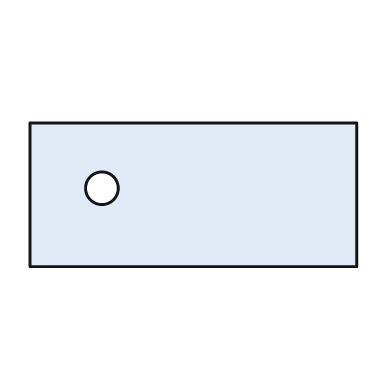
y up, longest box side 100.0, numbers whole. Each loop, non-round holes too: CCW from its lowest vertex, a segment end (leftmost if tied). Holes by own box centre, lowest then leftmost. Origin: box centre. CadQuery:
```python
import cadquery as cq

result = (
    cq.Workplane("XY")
    .moveTo(-50.0, -22.0)
    .lineTo(50.0, -22.0)
    .lineTo(50.0, 22.0)
    .lineTo(-50.0, 22.0)
    .close()
    .moveTo(-28.0, 2.0)
    .circle(5.0)
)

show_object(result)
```